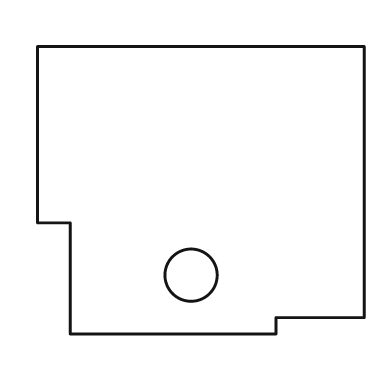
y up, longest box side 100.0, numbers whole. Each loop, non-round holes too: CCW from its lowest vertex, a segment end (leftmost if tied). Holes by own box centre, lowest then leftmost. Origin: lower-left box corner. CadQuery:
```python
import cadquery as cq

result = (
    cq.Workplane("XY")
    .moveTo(10.0, 0.0)
    .lineTo(73.0, 0.0)
    .lineTo(73.0, 5.0)
    .lineTo(100.0, 5.0)
    .lineTo(100.0, 88.0)
    .lineTo(0.0, 88.0)
    .lineTo(0.0, 34.0)
    .lineTo(10.0, 34.0)
    .close()
    .moveTo(47.0, 18.0)
    .circle(8.0)
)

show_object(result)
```